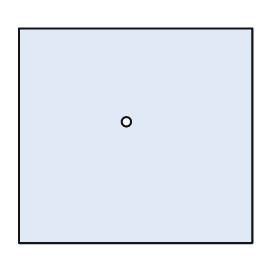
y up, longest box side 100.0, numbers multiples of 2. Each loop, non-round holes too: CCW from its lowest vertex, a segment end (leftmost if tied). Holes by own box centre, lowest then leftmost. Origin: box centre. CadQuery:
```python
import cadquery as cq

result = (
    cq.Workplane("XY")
    .moveTo(-50.0, -46.0)
    .lineTo(50.0, -46.0)
    .lineTo(50.0, 46.0)
    .lineTo(-50.0, 46.0)
    .close()
    .moveTo(-4.0, 6.0)
    .circle(2.0)
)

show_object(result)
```